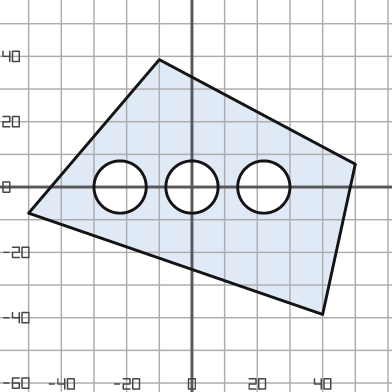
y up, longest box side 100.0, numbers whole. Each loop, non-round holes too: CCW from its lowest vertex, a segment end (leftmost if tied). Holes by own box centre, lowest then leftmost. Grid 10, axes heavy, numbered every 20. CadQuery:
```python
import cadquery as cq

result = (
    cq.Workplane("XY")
    .moveTo(40.0, -39.0)
    .lineTo(50.0, 7.0)
    .lineTo(-10.0, 39.0)
    .lineTo(-50.0, -8.0)
    .close()
    .moveTo(-22.0, 0.0)
    .circle(8.0)
    .moveTo(0.0, 0.0)
    .circle(8.0)
    .moveTo(22.0, 0.0)
    .circle(8.0)
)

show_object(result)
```